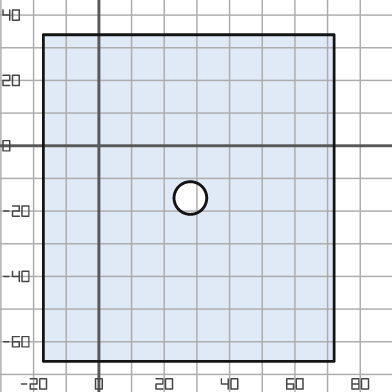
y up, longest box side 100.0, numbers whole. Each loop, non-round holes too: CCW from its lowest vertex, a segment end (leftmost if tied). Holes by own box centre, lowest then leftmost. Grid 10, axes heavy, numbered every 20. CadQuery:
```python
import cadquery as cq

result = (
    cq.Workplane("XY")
    .moveTo(-17.0, -66.0)
    .lineTo(72.0, -66.0)
    .lineTo(72.0, 34.0)
    .lineTo(-17.0, 34.0)
    .close()
    .moveTo(28.0, -16.0)
    .circle(5.0)
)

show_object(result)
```